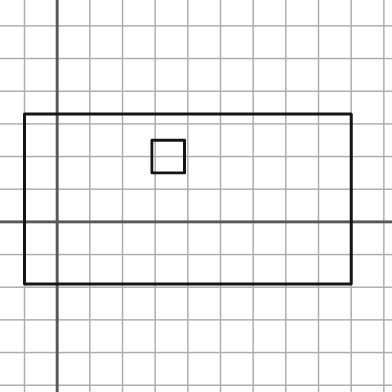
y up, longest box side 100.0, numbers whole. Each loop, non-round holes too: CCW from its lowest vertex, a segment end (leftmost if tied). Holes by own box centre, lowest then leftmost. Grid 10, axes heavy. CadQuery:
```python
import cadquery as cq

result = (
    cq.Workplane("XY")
    .moveTo(-10.0, -19.0)
    .lineTo(90.0, -19.0)
    .lineTo(90.0, 33.0)
    .lineTo(-10.0, 33.0)
    .close()
    .moveTo(29.0, 15.0)
    .lineTo(39.0, 15.0)
    .lineTo(39.0, 25.0)
    .lineTo(29.0, 25.0)
    .close()
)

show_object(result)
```